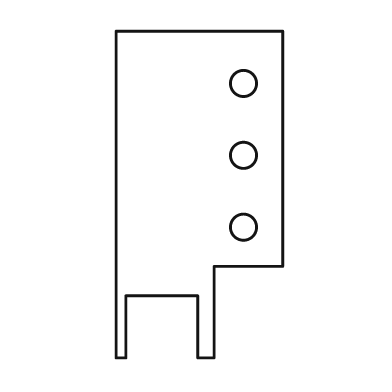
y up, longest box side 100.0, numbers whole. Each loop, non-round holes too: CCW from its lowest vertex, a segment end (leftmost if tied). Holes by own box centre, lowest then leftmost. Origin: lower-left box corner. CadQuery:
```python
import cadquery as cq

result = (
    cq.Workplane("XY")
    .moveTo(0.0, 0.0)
    .lineTo(3.0, 0.0)
    .lineTo(3.0, 19.0)
    .lineTo(25.0, 19.0)
    .lineTo(25.0, 0.0)
    .lineTo(30.0, 0.0)
    .lineTo(30.0, 28.0)
    .lineTo(51.0, 28.0)
    .lineTo(51.0, 100.0)
    .lineTo(0.0, 100.0)
    .close()
    .moveTo(39.0, 40.0)
    .circle(4.0)
    .moveTo(39.0, 62.0)
    .circle(4.0)
    .moveTo(39.0, 84.0)
    .circle(4.0)
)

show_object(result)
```